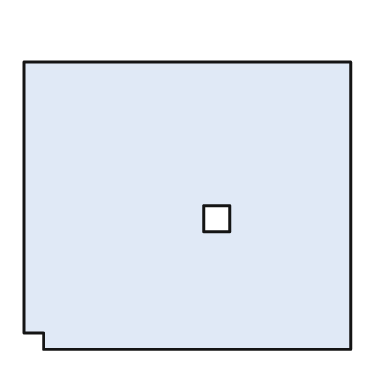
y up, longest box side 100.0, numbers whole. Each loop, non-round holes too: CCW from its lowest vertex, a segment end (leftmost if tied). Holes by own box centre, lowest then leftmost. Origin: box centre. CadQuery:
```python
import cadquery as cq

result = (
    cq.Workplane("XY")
    .moveTo(-44.0, -44.0)
    .lineTo(50.0, -44.0)
    .lineTo(50.0, 44.0)
    .lineTo(-50.0, 44.0)
    .lineTo(-50.0, -39.0)
    .lineTo(-44.0, -39.0)
    .close()
    .moveTo(5.0, -8.0)
    .lineTo(13.0, -8.0)
    .lineTo(13.0, 0.0)
    .lineTo(5.0, 0.0)
    .close()
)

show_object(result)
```